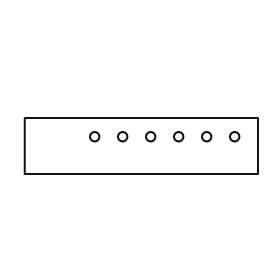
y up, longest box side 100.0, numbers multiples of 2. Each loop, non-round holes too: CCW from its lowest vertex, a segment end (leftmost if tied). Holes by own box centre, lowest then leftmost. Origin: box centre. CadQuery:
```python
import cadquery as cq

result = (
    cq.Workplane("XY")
    .moveTo(-50.0, -12.0)
    .lineTo(50.0, -12.0)
    .lineTo(50.0, 12.0)
    .lineTo(-50.0, 12.0)
    .close()
    .moveTo(-20.0, 4.0)
    .circle(2.0)
    .moveTo(-8.0, 4.0)
    .circle(2.0)
    .moveTo(4.0, 4.0)
    .circle(2.0)
    .moveTo(16.0, 4.0)
    .circle(2.0)
    .moveTo(28.0, 4.0)
    .circle(2.0)
    .moveTo(40.0, 4.0)
    .circle(2.0)
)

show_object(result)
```